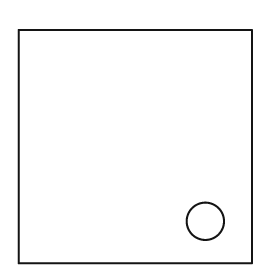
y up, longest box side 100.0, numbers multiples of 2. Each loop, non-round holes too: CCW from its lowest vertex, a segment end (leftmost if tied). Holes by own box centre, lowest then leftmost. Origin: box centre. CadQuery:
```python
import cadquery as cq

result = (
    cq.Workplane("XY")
    .moveTo(-50.0, -50.0)
    .lineTo(50.0, -50.0)
    .lineTo(50.0, 50.0)
    .lineTo(-50.0, 50.0)
    .close()
    .moveTo(30.0, -32.0)
    .circle(8.0)
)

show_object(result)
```